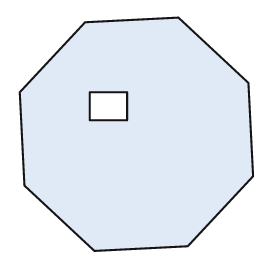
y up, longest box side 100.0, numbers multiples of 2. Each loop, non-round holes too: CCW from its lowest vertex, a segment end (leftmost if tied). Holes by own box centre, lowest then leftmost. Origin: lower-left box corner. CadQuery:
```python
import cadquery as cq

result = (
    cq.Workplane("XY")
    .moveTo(32.0, 0.0)
    .lineTo(72.0, 2.0)
    .lineTo(100.0, 32.0)
    .lineTo(98.0, 72.0)
    .lineTo(68.0, 100.0)
    .lineTo(28.0, 98.0)
    .lineTo(0.0, 68.0)
    .lineTo(2.0, 28.0)
    .close()
    .moveTo(30.0, 56.0)
    .lineTo(46.0, 56.0)
    .lineTo(46.0, 68.0)
    .lineTo(30.0, 68.0)
    .close()
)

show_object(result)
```